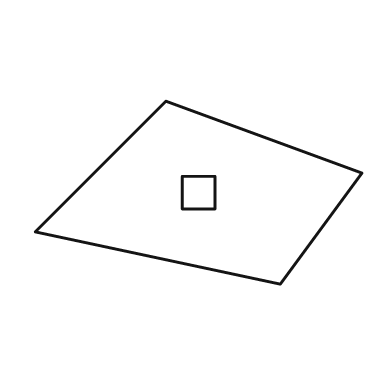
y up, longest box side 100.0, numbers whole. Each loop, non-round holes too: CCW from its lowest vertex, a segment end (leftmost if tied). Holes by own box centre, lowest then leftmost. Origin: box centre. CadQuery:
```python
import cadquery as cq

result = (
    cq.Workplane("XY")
    .moveTo(25.0, -28.0)
    .lineTo(50.0, 6.0)
    .lineTo(-10.0, 28.0)
    .lineTo(-50.0, -12.0)
    .close()
    .moveTo(-5.0, -5.0)
    .lineTo(5.0, -5.0)
    .lineTo(5.0, 5.0)
    .lineTo(-5.0, 5.0)
    .close()
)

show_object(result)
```